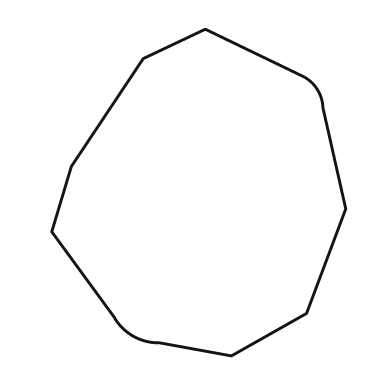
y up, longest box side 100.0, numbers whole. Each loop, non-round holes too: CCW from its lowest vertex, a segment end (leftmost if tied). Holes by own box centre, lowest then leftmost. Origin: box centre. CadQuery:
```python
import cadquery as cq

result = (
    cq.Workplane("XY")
    .moveTo(10.0, -50.0)
    .lineTo(33.0, -37.0)
    .lineTo(45.0, -5.0)
    .lineTo(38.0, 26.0)
    .threePointArc((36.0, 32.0), (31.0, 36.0))
    .lineTo(2.0, 50.0)
    .lineTo(-17.0, 41.0)
    .lineTo(-39.0, 8.0)
    .lineTo(-45.0, -12.0)
    .lineTo(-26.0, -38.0)
    .threePointArc((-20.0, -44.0), (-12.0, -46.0))
    .close()
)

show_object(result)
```